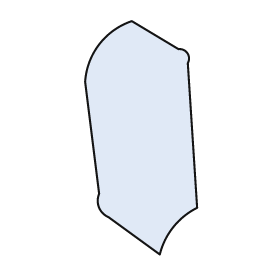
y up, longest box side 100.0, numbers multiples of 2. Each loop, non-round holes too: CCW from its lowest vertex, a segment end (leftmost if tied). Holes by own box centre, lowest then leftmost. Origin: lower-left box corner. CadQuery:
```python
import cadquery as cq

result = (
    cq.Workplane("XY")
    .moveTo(32.0, 0.0)
    .threePointArc((38.0, 12.0), (48.0, 20.0))
    .lineTo(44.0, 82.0)
    .threePointArc((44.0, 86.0), (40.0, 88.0))
    .lineTo(20.0, 100.0)
    .threePointArc((6.0, 90.0), (0.0, 74.0))
    .lineTo(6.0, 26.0)
    .threePointArc((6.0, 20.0), (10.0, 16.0))
    .close()
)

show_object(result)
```